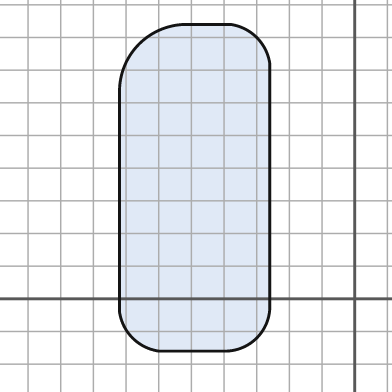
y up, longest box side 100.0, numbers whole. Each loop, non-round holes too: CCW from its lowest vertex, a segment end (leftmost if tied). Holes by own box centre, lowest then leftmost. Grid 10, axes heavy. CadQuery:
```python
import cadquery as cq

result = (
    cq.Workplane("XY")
    .moveTo(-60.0, -16.0)
    .lineTo(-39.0, -16.0)
    .threePointArc((-30.0, -12.0), (-26.0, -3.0))
    .lineTo(-26.0, 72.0)
    .threePointArc((-30.0, 80.0), (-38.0, 84.0))
    .lineTo(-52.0, 84.0)
    .threePointArc((-66.0, 78.0), (-72.0, 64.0))
    .lineTo(-72.0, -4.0)
    .threePointArc((-68.0, -12.0), (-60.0, -16.0))
    .close()
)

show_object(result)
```